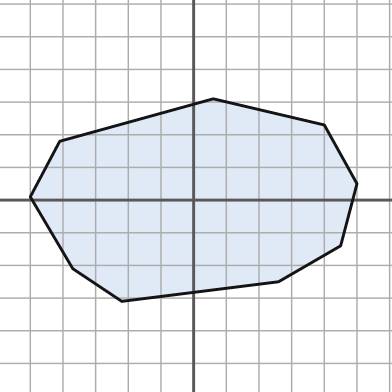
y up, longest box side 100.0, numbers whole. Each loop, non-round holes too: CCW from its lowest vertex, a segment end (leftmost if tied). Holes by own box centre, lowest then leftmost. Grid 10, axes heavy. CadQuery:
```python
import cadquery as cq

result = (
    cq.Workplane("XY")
    .moveTo(-22.0, -31.0)
    .lineTo(26.0, -25.0)
    .lineTo(45.0, -14.0)
    .lineTo(50.0, 5.0)
    .lineTo(40.0, 23.0)
    .lineTo(6.0, 31.0)
    .lineTo(-41.0, 18.0)
    .lineTo(-50.0, 1.0)
    .lineTo(-37.0, -21.0)
    .close()
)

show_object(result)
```